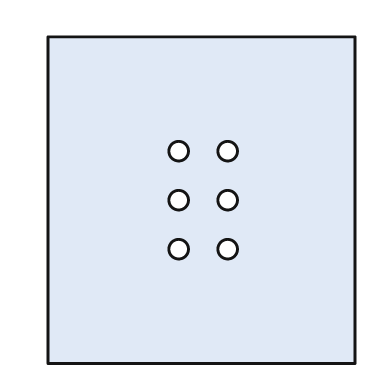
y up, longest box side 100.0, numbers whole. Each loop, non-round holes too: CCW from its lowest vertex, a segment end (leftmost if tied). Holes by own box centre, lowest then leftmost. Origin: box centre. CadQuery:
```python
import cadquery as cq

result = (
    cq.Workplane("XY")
    .moveTo(-47.0, -50.0)
    .lineTo(47.0, -50.0)
    .lineTo(47.0, 50.0)
    .lineTo(-47.0, 50.0)
    .close()
    .moveTo(-7.0, -15.0)
    .circle(3.0)
    .moveTo(8.0, -15.0)
    .circle(3.0)
    .moveTo(-7.0, 0.0)
    .circle(3.0)
    .moveTo(8.0, 0.0)
    .circle(3.0)
    .moveTo(-7.0, 15.0)
    .circle(3.0)
    .moveTo(8.0, 15.0)
    .circle(3.0)
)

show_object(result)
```